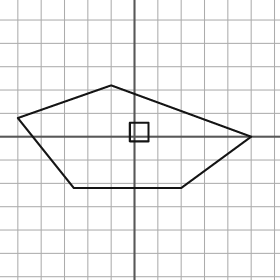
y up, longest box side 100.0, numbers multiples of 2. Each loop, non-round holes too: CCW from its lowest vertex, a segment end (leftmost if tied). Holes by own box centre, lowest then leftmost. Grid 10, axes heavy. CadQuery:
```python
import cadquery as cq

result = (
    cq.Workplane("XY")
    .moveTo(-26.0, -22.0)
    .lineTo(20.0, -22.0)
    .lineTo(50.0, 0.0)
    .lineTo(-10.0, 22.0)
    .lineTo(-50.0, 8.0)
    .close()
    .moveTo(-2.0, -2.0)
    .lineTo(6.0, -2.0)
    .lineTo(6.0, 6.0)
    .lineTo(-2.0, 6.0)
    .close()
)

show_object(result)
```